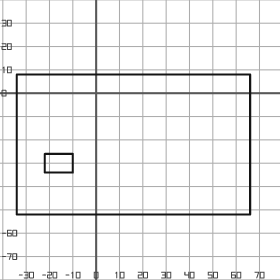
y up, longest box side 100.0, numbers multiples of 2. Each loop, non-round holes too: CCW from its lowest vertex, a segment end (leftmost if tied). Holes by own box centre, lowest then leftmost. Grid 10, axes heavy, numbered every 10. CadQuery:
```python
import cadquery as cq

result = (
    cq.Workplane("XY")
    .moveTo(-34.0, -52.0)
    .lineTo(66.0, -52.0)
    .lineTo(66.0, 8.0)
    .lineTo(-34.0, 8.0)
    .close()
    .moveTo(-22.0, -34.0)
    .lineTo(-10.0, -34.0)
    .lineTo(-10.0, -26.0)
    .lineTo(-22.0, -26.0)
    .close()
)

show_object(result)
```